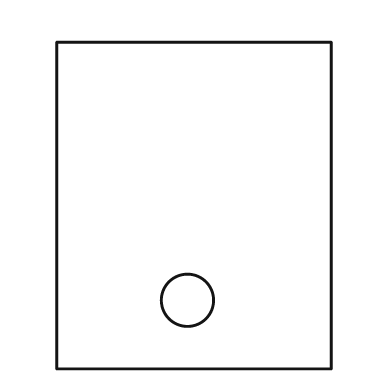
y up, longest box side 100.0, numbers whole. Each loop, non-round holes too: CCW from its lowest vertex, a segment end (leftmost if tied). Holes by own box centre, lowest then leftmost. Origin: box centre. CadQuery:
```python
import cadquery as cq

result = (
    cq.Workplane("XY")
    .moveTo(-42.0, -50.0)
    .lineTo(42.0, -50.0)
    .lineTo(42.0, 50.0)
    .lineTo(-42.0, 50.0)
    .close()
    .moveTo(-2.0, -29.0)
    .circle(8.0)
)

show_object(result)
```